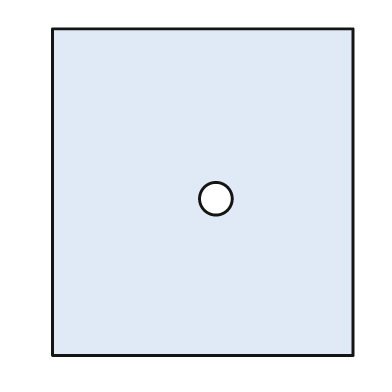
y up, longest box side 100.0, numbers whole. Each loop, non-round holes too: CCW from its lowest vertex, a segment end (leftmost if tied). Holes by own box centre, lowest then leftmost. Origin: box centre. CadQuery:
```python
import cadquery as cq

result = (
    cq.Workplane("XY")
    .moveTo(-46.0, -50.0)
    .lineTo(46.0, -50.0)
    .lineTo(46.0, 50.0)
    .lineTo(-46.0, 50.0)
    .close()
    .moveTo(4.0, -2.0)
    .circle(5.0)
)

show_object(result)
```